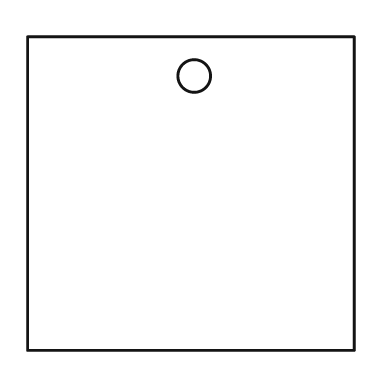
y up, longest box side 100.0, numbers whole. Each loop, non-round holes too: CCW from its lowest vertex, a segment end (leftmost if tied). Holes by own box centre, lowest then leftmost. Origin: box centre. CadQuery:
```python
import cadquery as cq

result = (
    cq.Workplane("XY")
    .moveTo(-50.0, -48.0)
    .lineTo(50.0, -48.0)
    .lineTo(50.0, 48.0)
    .lineTo(-50.0, 48.0)
    .close()
    .moveTo(1.0, 36.0)
    .circle(5.0)
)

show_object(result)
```